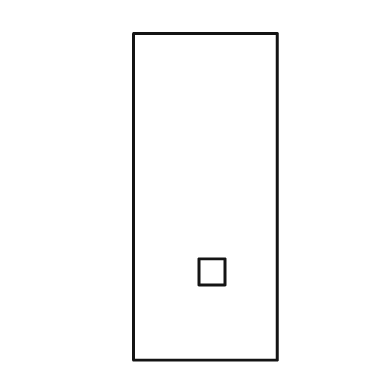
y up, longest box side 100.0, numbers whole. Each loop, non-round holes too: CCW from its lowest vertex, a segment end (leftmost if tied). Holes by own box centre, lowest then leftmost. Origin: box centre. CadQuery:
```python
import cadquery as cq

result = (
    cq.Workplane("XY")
    .moveTo(-22.0, -50.0)
    .lineTo(22.0, -50.0)
    .lineTo(22.0, 50.0)
    .lineTo(-22.0, 50.0)
    .close()
    .moveTo(-2.0, -27.0)
    .lineTo(6.0, -27.0)
    .lineTo(6.0, -19.0)
    .lineTo(-2.0, -19.0)
    .close()
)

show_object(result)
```